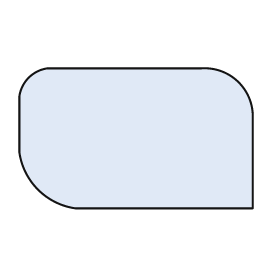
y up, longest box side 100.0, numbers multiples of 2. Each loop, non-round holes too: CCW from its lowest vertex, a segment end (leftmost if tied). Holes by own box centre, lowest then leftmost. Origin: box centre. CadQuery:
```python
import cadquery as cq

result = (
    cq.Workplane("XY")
    .moveTo(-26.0, -30.0)
    .lineTo(50.0, -30.0)
    .lineTo(50.0, 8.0)
    .threePointArc((44.0, 24.0), (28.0, 30.0))
    .lineTo(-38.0, 30.0)
    .threePointArc((-46.0, 26.0), (-50.0, 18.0))
    .lineTo(-50.0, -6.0)
    .threePointArc((-42.0, -22.0), (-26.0, -30.0))
    .close()
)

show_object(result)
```